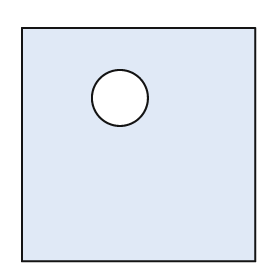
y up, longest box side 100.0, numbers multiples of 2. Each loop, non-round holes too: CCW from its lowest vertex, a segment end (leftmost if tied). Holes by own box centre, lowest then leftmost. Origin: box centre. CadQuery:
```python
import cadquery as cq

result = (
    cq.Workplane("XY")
    .moveTo(-50.0, -50.0)
    .lineTo(50.0, -50.0)
    .lineTo(50.0, 50.0)
    .lineTo(-50.0, 50.0)
    .close()
    .moveTo(-8.0, 20.0)
    .circle(12.0)
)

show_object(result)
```